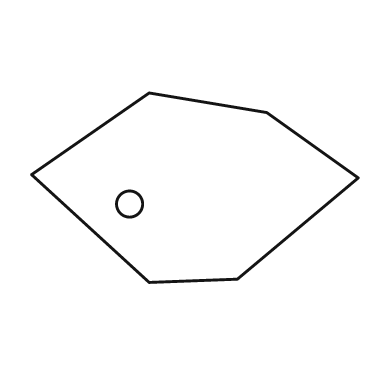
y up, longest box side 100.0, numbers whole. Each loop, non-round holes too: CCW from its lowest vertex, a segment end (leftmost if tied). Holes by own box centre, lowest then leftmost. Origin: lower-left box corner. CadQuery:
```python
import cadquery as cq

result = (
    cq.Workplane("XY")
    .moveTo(36.0, 0.0)
    .lineTo(63.0, 1.0)
    .lineTo(100.0, 32.0)
    .lineTo(72.0, 52.0)
    .lineTo(36.0, 58.0)
    .lineTo(0.0, 33.0)
    .close()
    .moveTo(30.0, 24.0)
    .circle(4.0)
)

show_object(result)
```